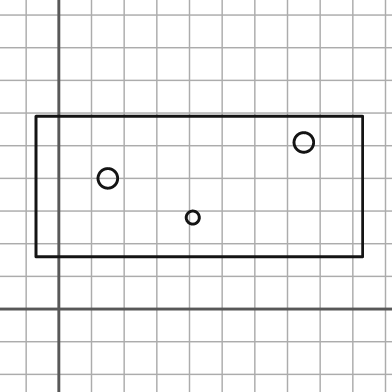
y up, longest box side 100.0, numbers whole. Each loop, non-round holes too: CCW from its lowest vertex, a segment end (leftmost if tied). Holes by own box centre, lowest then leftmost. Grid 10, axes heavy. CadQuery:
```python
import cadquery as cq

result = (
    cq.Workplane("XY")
    .moveTo(-7.0, 16.0)
    .lineTo(93.0, 16.0)
    .lineTo(93.0, 59.0)
    .lineTo(-7.0, 59.0)
    .close()
    .moveTo(41.0, 28.0)
    .circle(2.0)
    .moveTo(15.0, 40.0)
    .circle(3.0)
    .moveTo(75.0, 51.0)
    .circle(3.0)
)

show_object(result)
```